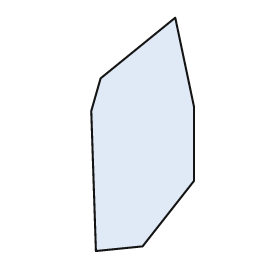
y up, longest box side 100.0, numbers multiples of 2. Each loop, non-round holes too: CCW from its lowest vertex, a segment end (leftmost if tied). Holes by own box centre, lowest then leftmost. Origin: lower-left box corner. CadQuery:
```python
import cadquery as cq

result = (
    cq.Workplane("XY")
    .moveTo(2.0, 0.0)
    .lineTo(22.0, 2.0)
    .lineTo(44.0, 30.0)
    .lineTo(44.0, 62.0)
    .lineTo(36.0, 100.0)
    .lineTo(4.0, 74.0)
    .lineTo(0.0, 60.0)
    .close()
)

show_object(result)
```